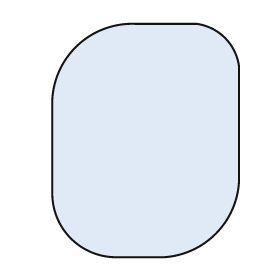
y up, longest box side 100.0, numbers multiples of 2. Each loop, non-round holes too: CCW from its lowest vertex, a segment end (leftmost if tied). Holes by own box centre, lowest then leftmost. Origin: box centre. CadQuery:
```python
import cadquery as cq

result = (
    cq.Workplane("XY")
    .moveTo(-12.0, -50.0)
    .lineTo(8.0, -50.0)
    .threePointArc((30.0, -40.0), (40.0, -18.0))
    .lineTo(40.0, 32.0)
    .threePointArc((34.0, 44.0), (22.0, 50.0))
    .lineTo(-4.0, 50.0)
    .threePointArc((-30.0, 40.0), (-40.0, 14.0))
    .lineTo(-40.0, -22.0)
    .threePointArc((-32.0, -42.0), (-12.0, -50.0))
    .close()
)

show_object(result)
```